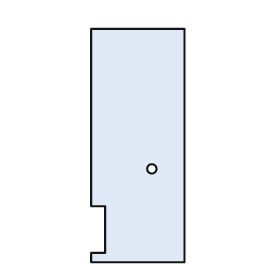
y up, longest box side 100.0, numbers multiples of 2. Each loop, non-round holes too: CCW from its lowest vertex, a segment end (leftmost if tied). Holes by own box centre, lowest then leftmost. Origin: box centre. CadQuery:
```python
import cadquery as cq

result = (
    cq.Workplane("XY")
    .moveTo(-20.0, -50.0)
    .lineTo(20.0, -50.0)
    .lineTo(20.0, 50.0)
    .lineTo(-20.0, 50.0)
    .lineTo(-20.0, -26.0)
    .lineTo(-14.0, -26.0)
    .lineTo(-14.0, -46.0)
    .lineTo(-20.0, -46.0)
    .close()
    .moveTo(6.0, -10.0)
    .circle(2.0)
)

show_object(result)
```